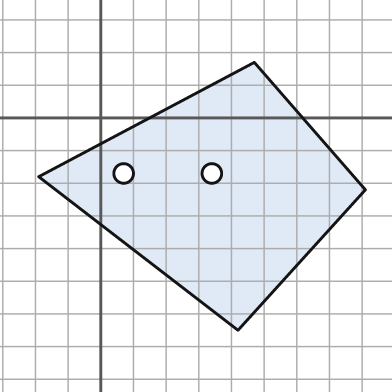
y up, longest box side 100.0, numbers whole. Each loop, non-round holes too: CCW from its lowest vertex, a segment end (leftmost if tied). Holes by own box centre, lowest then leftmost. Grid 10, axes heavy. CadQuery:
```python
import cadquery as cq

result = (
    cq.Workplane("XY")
    .moveTo(42.0, -65.0)
    .lineTo(81.0, -22.0)
    .lineTo(47.0, 17.0)
    .lineTo(-19.0, -18.0)
    .close()
    .moveTo(7.0, -17.0)
    .circle(3.0)
    .moveTo(34.0, -17.0)
    .circle(3.0)
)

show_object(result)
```